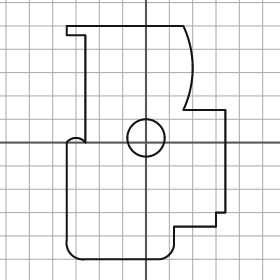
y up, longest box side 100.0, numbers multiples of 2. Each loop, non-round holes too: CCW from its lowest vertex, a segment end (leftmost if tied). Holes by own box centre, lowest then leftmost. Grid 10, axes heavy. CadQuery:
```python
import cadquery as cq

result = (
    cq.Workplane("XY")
    .moveTo(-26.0, -50.0)
    .lineTo(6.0, -50.0)
    .threePointArc((10.0, -48.0), (12.0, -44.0))
    .lineTo(12.0, -36.0)
    .lineTo(30.0, -36.0)
    .lineTo(30.0, -30.0)
    .lineTo(34.0, -30.0)
    .lineTo(34.0, 14.0)
    .lineTo(16.0, 14.0)
    .threePointArc((20.0, 32.0), (16.0, 50.0))
    .lineTo(-34.0, 50.0)
    .lineTo(-34.0, 46.0)
    .lineTo(-26.0, 46.0)
    .lineTo(-26.0, 0.0)
    .threePointArc((-30.0, 2.0), (-34.0, 0.0))
    .lineTo(-34.0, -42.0)
    .threePointArc((-32.0, -48.0), (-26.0, -50.0))
    .close()
    .moveTo(0.0, 2.0)
    .circle(8.0)
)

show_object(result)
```